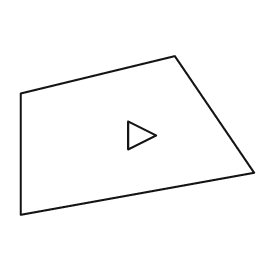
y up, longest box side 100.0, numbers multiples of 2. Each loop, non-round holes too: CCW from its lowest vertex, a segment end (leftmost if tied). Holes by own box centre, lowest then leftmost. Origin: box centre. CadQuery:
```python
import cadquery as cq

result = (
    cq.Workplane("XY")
    .moveTo(-50.0, -34.0)
    .lineTo(50.0, -16.0)
    .lineTo(16.0, 34.0)
    .lineTo(-50.0, 18.0)
    .close()
    .moveTo(-4.0, -6.0)
    .lineTo(8.0, 0.0)
    .lineTo(-4.0, 6.0)
    .close()
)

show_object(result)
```